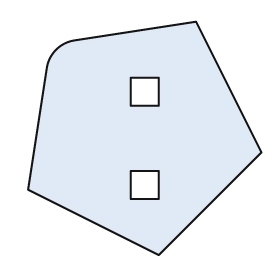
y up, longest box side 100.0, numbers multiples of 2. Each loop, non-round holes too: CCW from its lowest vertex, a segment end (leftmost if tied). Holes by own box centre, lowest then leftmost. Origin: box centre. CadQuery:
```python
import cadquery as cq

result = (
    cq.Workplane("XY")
    .moveTo(6.0, -50.0)
    .lineTo(50.0, -6.0)
    .lineTo(22.0, 50.0)
    .lineTo(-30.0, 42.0)
    .threePointArc((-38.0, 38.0), (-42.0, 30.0))
    .lineTo(-50.0, -22.0)
    .close()
    .moveTo(-6.0, -26.0)
    .lineTo(6.0, -26.0)
    .lineTo(6.0, -14.0)
    .lineTo(-6.0, -14.0)
    .close()
    .moveTo(-6.0, 14.0)
    .lineTo(6.0, 14.0)
    .lineTo(6.0, 26.0)
    .lineTo(-6.0, 26.0)
    .close()
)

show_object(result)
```